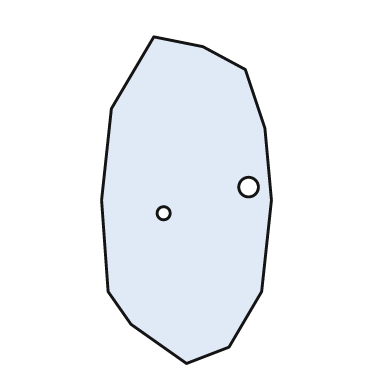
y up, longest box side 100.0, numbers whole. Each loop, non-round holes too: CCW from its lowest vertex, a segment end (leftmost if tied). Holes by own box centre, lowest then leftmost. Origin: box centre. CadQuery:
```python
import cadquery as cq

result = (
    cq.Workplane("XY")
    .moveTo(0.0, -50.0)
    .lineTo(13.0, -45.0)
    .lineTo(23.0, -28.0)
    .lineTo(26.0, 0.0)
    .lineTo(24.0, 22.0)
    .lineTo(18.0, 40.0)
    .lineTo(5.0, 47.0)
    .lineTo(-10.0, 50.0)
    .lineTo(-23.0, 28.0)
    .lineTo(-26.0, 0.0)
    .lineTo(-24.0, -28.0)
    .lineTo(-17.0, -38.0)
    .close()
    .moveTo(-7.0, -4.0)
    .circle(2.0)
    .moveTo(19.0, 4.0)
    .circle(3.0)
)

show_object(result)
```